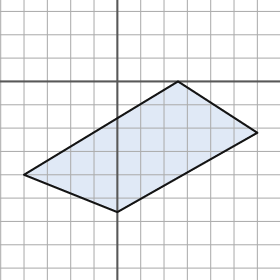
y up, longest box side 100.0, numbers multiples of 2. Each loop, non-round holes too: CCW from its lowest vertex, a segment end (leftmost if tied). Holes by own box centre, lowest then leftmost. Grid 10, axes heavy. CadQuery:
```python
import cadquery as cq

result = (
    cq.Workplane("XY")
    .moveTo(0.0, -56.0)
    .lineTo(60.0, -22.0)
    .lineTo(26.0, 0.0)
    .lineTo(-40.0, -40.0)
    .close()
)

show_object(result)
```